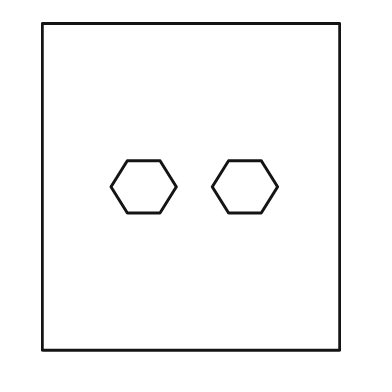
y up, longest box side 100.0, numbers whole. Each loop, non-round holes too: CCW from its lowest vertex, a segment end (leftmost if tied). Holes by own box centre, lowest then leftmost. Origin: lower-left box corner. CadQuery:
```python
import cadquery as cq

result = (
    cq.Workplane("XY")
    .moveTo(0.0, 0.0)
    .lineTo(91.0, 0.0)
    .lineTo(91.0, 100.0)
    .lineTo(0.0, 100.0)
    .close()
    .moveTo(26.0, 42.0)
    .lineTo(36.0, 42.0)
    .lineTo(41.0, 50.0)
    .lineTo(36.0, 58.0)
    .lineTo(26.0, 58.0)
    .lineTo(21.0, 50.0)
    .close()
    .moveTo(57.0, 42.0)
    .lineTo(67.0, 42.0)
    .lineTo(72.0, 50.0)
    .lineTo(67.0, 58.0)
    .lineTo(57.0, 58.0)
    .lineTo(52.0, 50.0)
    .close()
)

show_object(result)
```